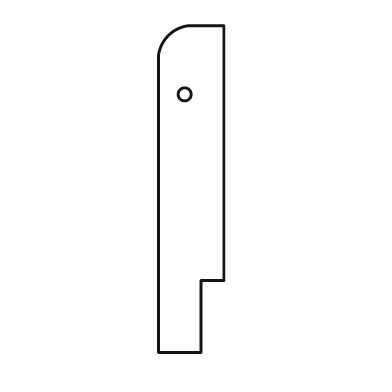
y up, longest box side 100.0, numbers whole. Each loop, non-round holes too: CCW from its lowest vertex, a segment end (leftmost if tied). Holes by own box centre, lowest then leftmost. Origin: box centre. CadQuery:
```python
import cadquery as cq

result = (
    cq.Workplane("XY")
    .moveTo(-10.0, -50.0)
    .lineTo(3.0, -50.0)
    .lineTo(3.0, -28.0)
    .lineTo(10.0, -28.0)
    .lineTo(10.0, 50.0)
    .lineTo(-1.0, 50.0)
    .threePointArc((-7.0, 47.0), (-10.0, 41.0))
    .close()
    .moveTo(-2.0, 29.0)
    .circle(2.0)
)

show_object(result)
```